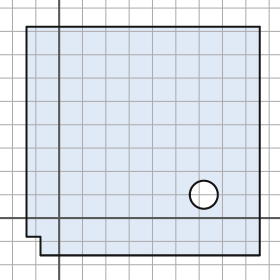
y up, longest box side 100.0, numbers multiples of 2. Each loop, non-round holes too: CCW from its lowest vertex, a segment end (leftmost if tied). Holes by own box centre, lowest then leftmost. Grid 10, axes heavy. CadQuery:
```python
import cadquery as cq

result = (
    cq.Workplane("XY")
    .moveTo(-8.0, -16.0)
    .lineTo(86.0, -16.0)
    .lineTo(86.0, 82.0)
    .lineTo(-14.0, 82.0)
    .lineTo(-14.0, -8.0)
    .lineTo(-8.0, -8.0)
    .close()
    .moveTo(62.0, 10.0)
    .circle(6.0)
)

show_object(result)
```